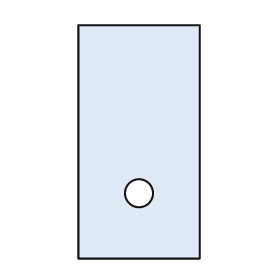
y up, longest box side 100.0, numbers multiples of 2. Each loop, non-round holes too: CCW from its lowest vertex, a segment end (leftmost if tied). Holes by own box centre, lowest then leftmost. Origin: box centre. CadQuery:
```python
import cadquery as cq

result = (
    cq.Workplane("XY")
    .moveTo(-26.0, -50.0)
    .lineTo(26.0, -50.0)
    .lineTo(26.0, 50.0)
    .lineTo(-26.0, 50.0)
    .close()
    .moveTo(0.0, -22.0)
    .circle(6.0)
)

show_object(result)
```